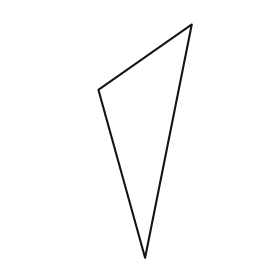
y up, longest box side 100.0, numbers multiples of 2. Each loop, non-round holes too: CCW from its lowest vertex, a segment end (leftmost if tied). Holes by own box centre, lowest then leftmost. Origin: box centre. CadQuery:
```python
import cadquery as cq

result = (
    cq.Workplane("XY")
    .moveTo(0.0, -50.0)
    .lineTo(20.0, 50.0)
    .lineTo(-20.0, 22.0)
    .close()
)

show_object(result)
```